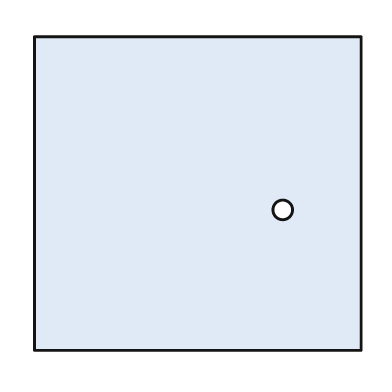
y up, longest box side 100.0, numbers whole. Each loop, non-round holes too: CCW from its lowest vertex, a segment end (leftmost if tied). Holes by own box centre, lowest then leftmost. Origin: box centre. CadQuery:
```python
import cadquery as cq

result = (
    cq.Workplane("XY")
    .moveTo(-50.0, -48.0)
    .lineTo(50.0, -48.0)
    .lineTo(50.0, 48.0)
    .lineTo(-50.0, 48.0)
    .close()
    .moveTo(26.0, -5.0)
    .circle(3.0)
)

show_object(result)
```